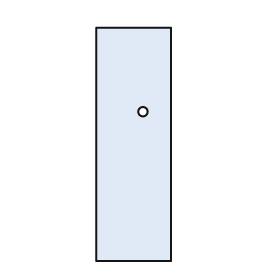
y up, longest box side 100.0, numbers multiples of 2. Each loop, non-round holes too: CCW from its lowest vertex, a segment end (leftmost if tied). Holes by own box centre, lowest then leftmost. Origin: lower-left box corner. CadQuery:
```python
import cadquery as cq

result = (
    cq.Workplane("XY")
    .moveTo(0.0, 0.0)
    .lineTo(32.0, 0.0)
    .lineTo(32.0, 100.0)
    .lineTo(0.0, 100.0)
    .close()
    .moveTo(20.0, 64.0)
    .circle(2.0)
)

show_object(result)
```